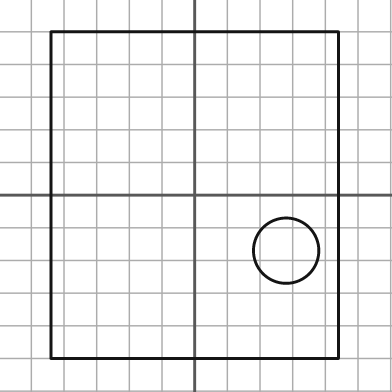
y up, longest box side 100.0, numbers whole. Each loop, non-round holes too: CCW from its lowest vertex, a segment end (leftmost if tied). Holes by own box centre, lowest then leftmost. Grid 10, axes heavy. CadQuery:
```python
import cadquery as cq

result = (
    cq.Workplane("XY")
    .moveTo(-44.0, -50.0)
    .lineTo(44.0, -50.0)
    .lineTo(44.0, 50.0)
    .lineTo(-44.0, 50.0)
    .close()
    .moveTo(28.0, -17.0)
    .circle(10.0)
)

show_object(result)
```